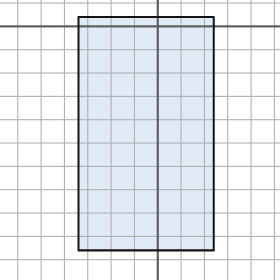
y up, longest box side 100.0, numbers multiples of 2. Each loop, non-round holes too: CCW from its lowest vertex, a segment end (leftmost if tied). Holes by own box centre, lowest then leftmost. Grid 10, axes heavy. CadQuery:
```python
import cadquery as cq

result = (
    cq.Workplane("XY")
    .moveTo(-34.0, -96.0)
    .lineTo(24.0, -96.0)
    .lineTo(24.0, 4.0)
    .lineTo(-34.0, 4.0)
    .close()
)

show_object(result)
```